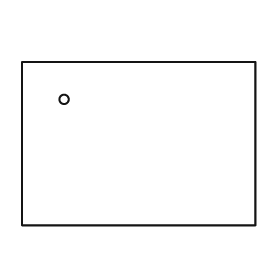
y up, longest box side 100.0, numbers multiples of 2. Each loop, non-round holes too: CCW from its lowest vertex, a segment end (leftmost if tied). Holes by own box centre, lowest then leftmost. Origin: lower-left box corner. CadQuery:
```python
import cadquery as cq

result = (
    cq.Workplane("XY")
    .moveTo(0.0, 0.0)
    .lineTo(100.0, 0.0)
    .lineTo(100.0, 70.0)
    .lineTo(0.0, 70.0)
    .close()
    .moveTo(18.0, 54.0)
    .circle(2.0)
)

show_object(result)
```